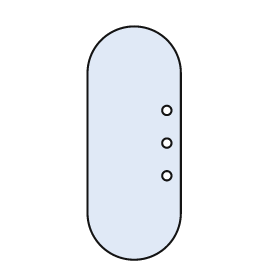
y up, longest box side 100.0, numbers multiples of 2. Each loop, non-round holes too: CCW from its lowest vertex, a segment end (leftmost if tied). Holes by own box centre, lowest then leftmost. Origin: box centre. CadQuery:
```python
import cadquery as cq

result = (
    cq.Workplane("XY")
    .moveTo(-20.0, -30.0)
    .threePointArc((0.0, -50.0), (20.0, -30.0))
    .lineTo(20.0, 30.0)
    .threePointArc((0.0, 50.0), (-20.0, 30.0))
    .close()
    .moveTo(14.0, -14.0)
    .circle(2.0)
    .moveTo(14.0, 0.0)
    .circle(2.0)
    .moveTo(14.0, 14.0)
    .circle(2.0)
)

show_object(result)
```